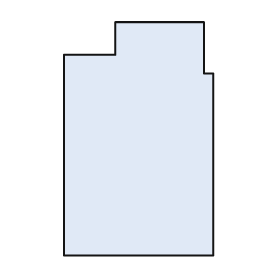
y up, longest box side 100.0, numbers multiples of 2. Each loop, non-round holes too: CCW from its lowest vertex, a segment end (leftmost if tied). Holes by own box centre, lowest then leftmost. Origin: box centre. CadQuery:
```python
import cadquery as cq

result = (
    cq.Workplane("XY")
    .moveTo(-32.0, -50.0)
    .lineTo(32.0, -50.0)
    .lineTo(32.0, 28.0)
    .lineTo(28.0, 28.0)
    .lineTo(28.0, 50.0)
    .lineTo(-10.0, 50.0)
    .lineTo(-10.0, 36.0)
    .lineTo(-32.0, 36.0)
    .close()
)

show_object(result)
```